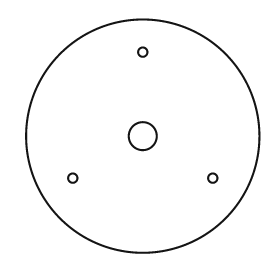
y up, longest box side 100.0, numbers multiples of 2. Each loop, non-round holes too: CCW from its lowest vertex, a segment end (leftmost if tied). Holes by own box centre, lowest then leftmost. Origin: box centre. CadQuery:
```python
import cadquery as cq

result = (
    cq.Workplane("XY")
    .moveTo(0.0, 0.0)
    .circle(50.0)
    .moveTo(-30.0, -18.0)
    .circle(2.0)
    .moveTo(30.0, -18.0)
    .circle(2.0)
    .moveTo(0.0, 0.0)
    .circle(6.0)
    .moveTo(0.0, 36.0)
    .circle(2.0)
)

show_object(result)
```